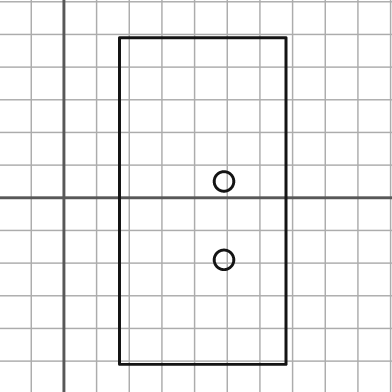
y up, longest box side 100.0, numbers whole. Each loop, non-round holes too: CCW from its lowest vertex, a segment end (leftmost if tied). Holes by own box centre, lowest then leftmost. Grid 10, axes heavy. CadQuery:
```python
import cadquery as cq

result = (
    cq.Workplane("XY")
    .moveTo(17.0, -51.0)
    .lineTo(68.0, -51.0)
    .lineTo(68.0, 49.0)
    .lineTo(17.0, 49.0)
    .close()
    .moveTo(49.0, -19.0)
    .circle(3.0)
    .moveTo(49.0, 5.0)
    .circle(3.0)
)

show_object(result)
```